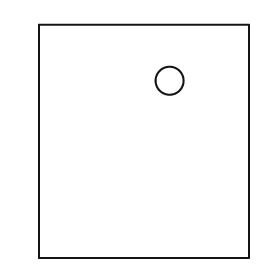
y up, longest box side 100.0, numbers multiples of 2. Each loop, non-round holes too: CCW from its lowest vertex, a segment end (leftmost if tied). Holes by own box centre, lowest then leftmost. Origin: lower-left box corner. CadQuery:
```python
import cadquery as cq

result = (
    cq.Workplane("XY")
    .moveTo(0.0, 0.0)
    .lineTo(90.0, 0.0)
    .lineTo(90.0, 100.0)
    .lineTo(0.0, 100.0)
    .close()
    .moveTo(56.0, 76.0)
    .circle(6.0)
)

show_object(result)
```